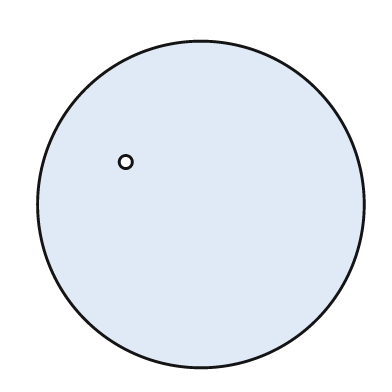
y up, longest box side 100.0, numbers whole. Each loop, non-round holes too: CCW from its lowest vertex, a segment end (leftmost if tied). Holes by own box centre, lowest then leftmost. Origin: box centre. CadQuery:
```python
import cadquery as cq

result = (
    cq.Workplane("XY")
    .moveTo(0.0, 0.0)
    .circle(50.0)
    .moveTo(-23.0, 13.0)
    .circle(2.0)
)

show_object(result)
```